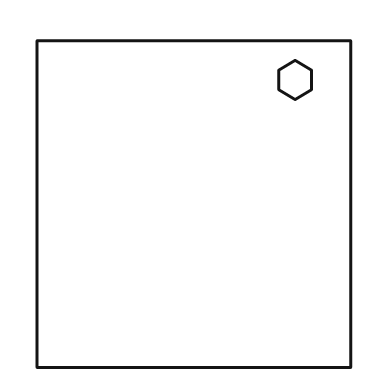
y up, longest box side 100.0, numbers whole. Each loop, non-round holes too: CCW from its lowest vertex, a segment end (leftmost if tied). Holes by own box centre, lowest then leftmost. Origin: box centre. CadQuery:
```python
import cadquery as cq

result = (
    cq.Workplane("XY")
    .moveTo(-48.0, -50.0)
    .lineTo(48.0, -50.0)
    .lineTo(48.0, 50.0)
    .lineTo(-48.0, 50.0)
    .close()
    .moveTo(31.0, 32.0)
    .lineTo(36.0, 35.0)
    .lineTo(36.0, 41.0)
    .lineTo(31.0, 44.0)
    .lineTo(26.0, 41.0)
    .lineTo(26.0, 35.0)
    .close()
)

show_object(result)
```